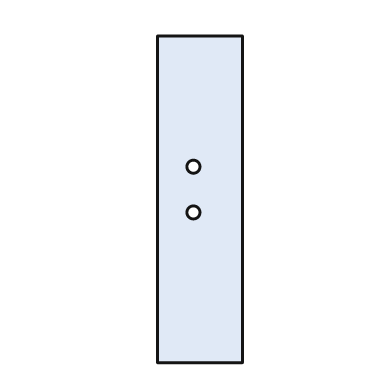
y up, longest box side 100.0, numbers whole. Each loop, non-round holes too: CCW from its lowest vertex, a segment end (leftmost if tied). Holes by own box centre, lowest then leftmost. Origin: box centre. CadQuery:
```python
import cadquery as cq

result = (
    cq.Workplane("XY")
    .moveTo(-13.0, -50.0)
    .lineTo(13.0, -50.0)
    .lineTo(13.0, 50.0)
    .lineTo(-13.0, 50.0)
    .close()
    .moveTo(-2.0, -4.0)
    .circle(2.0)
    .moveTo(-2.0, 10.0)
    .circle(2.0)
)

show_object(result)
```